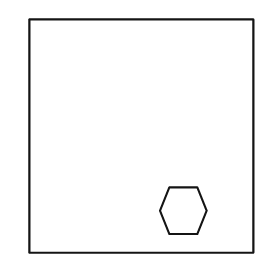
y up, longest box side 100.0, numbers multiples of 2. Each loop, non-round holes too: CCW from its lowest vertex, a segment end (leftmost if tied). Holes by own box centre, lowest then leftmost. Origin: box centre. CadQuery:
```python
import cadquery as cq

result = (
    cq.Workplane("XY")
    .moveTo(-48.0, -50.0)
    .lineTo(48.0, -50.0)
    .lineTo(48.0, 50.0)
    .lineTo(-48.0, 50.0)
    .close()
    .moveTo(12.0, -42.0)
    .lineTo(24.0, -42.0)
    .lineTo(28.0, -32.0)
    .lineTo(24.0, -22.0)
    .lineTo(12.0, -22.0)
    .lineTo(8.0, -32.0)
    .close()
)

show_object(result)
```